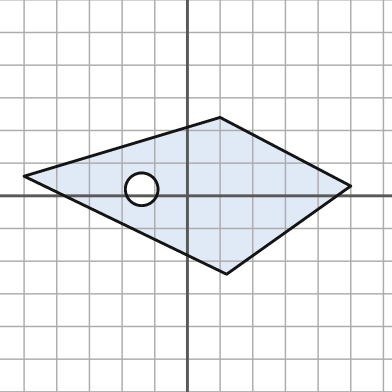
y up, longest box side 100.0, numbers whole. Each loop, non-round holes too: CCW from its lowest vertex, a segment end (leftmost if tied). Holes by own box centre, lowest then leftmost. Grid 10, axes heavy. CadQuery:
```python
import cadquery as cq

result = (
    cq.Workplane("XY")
    .moveTo(12.0, -24.0)
    .lineTo(50.0, 3.0)
    .lineTo(10.0, 24.0)
    .lineTo(-50.0, 6.0)
    .close()
    .moveTo(-14.0, 2.0)
    .circle(5.0)
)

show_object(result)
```